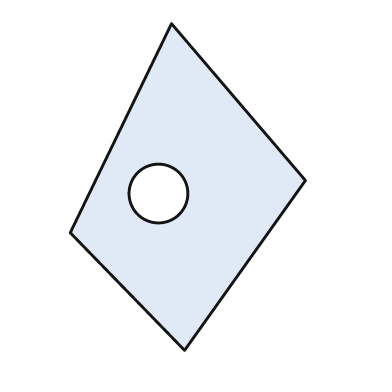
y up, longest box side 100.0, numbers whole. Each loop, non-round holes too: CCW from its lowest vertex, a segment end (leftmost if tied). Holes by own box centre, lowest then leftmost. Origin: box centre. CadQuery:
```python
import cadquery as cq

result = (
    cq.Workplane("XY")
    .moveTo(-1.0, -50.0)
    .lineTo(36.0, 2.0)
    .lineTo(-5.0, 50.0)
    .lineTo(-36.0, -14.0)
    .close()
    .moveTo(-9.0, -2.0)
    .circle(9.0)
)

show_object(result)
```